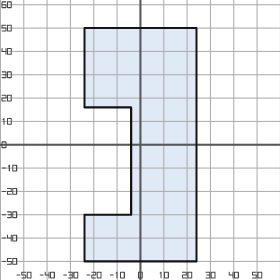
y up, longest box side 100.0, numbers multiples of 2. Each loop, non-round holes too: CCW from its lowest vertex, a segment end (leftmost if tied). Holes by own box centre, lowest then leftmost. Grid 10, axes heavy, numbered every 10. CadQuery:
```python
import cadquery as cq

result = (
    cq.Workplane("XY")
    .moveTo(-24.0, -50.0)
    .lineTo(24.0, -50.0)
    .lineTo(24.0, 50.0)
    .lineTo(-24.0, 50.0)
    .lineTo(-24.0, 16.0)
    .lineTo(-4.0, 16.0)
    .lineTo(-4.0, -30.0)
    .lineTo(-24.0, -30.0)
    .close()
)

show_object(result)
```